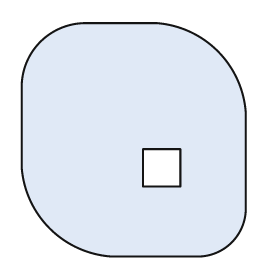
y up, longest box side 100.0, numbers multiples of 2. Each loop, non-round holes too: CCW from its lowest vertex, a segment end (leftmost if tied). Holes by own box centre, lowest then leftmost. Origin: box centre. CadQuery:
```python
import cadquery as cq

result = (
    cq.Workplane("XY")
    .moveTo(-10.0, -50.0)
    .lineTo(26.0, -50.0)
    .threePointArc((42.0, -44.0), (48.0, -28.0))
    .lineTo(48.0, 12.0)
    .threePointArc((36.0, 38.0), (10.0, 50.0))
    .lineTo(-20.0, 50.0)
    .threePointArc((-40.0, 42.0), (-48.0, 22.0))
    .lineTo(-48.0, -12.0)
    .threePointArc((-36.0, -38.0), (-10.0, -50.0))
    .close()
    .moveTo(4.0, -20.0)
    .lineTo(20.0, -20.0)
    .lineTo(20.0, -4.0)
    .lineTo(4.0, -4.0)
    .close()
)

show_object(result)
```